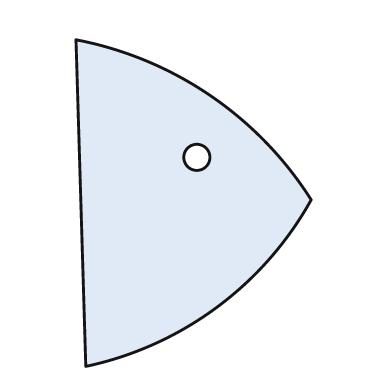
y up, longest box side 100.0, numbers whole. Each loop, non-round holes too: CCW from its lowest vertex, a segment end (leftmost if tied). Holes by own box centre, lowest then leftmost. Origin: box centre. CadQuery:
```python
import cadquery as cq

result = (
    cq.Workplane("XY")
    .moveTo(-33.0, -50.0)
    .threePointArc((7.0, -32.0), (36.0, 1.0))
    .threePointArc((5.0, 33.0), (-36.0, 50.0))
    .close()
    .moveTo(1.0, 14.0)
    .circle(4.0)
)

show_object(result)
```